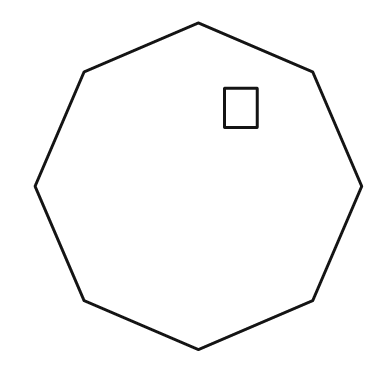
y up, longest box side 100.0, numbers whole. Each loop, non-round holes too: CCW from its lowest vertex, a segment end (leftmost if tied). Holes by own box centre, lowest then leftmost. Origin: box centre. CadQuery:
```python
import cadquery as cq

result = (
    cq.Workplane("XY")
    .moveTo(0.0, -50.0)
    .lineTo(35.0, -35.0)
    .lineTo(50.0, 0.0)
    .lineTo(35.0, 35.0)
    .lineTo(0.0, 50.0)
    .lineTo(-35.0, 35.0)
    .lineTo(-50.0, 0.0)
    .lineTo(-35.0, -35.0)
    .close()
    .moveTo(8.0, 18.0)
    .lineTo(18.0, 18.0)
    .lineTo(18.0, 30.0)
    .lineTo(8.0, 30.0)
    .close()
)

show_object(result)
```